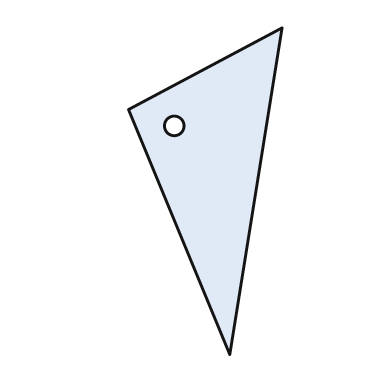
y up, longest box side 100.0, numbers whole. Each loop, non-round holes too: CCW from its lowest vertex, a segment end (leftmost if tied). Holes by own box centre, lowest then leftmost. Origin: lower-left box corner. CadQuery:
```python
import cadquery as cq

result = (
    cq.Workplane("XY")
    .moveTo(31.0, 0.0)
    .lineTo(47.0, 100.0)
    .lineTo(0.0, 75.0)
    .close()
    .moveTo(14.0, 70.0)
    .circle(3.0)
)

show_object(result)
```